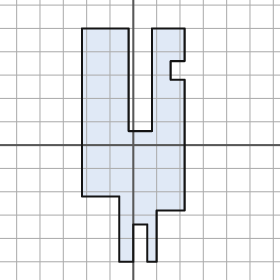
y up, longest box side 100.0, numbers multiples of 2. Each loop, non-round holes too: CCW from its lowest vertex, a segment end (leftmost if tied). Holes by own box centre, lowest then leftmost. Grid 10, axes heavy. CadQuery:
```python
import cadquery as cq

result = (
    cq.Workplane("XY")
    .moveTo(-6.0, -50.0)
    .lineTo(0.0, -50.0)
    .lineTo(0.0, -34.0)
    .lineTo(6.0, -34.0)
    .lineTo(6.0, -50.0)
    .lineTo(10.0, -50.0)
    .lineTo(10.0, -28.0)
    .lineTo(22.0, -28.0)
    .lineTo(22.0, 28.0)
    .lineTo(16.0, 28.0)
    .lineTo(16.0, 36.0)
    .lineTo(22.0, 36.0)
    .lineTo(22.0, 50.0)
    .lineTo(8.0, 50.0)
    .lineTo(8.0, 6.0)
    .lineTo(-2.0, 6.0)
    .lineTo(-2.0, 50.0)
    .lineTo(-22.0, 50.0)
    .lineTo(-22.0, -22.0)
    .lineTo(-6.0, -22.0)
    .close()
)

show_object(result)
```